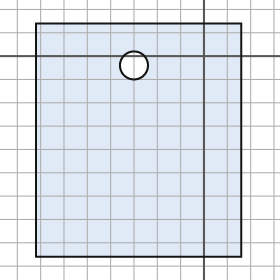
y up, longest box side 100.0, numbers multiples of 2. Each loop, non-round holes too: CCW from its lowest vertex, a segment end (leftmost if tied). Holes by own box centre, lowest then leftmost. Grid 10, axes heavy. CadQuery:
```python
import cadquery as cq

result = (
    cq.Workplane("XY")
    .moveTo(-72.0, -86.0)
    .lineTo(16.0, -86.0)
    .lineTo(16.0, 14.0)
    .lineTo(-72.0, 14.0)
    .close()
    .moveTo(-30.0, -4.0)
    .circle(6.0)
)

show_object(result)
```